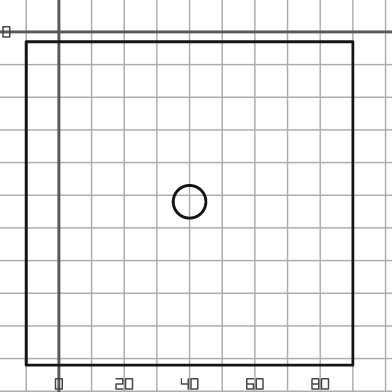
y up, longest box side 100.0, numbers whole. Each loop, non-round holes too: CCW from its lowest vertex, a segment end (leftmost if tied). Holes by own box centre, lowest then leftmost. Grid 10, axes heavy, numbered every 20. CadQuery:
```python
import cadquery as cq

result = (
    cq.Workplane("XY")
    .moveTo(-10.0, -102.0)
    .lineTo(90.0, -102.0)
    .lineTo(90.0, -3.0)
    .lineTo(-10.0, -3.0)
    .close()
    .moveTo(40.0, -52.0)
    .circle(5.0)
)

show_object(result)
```